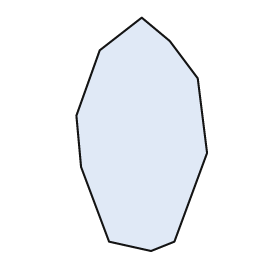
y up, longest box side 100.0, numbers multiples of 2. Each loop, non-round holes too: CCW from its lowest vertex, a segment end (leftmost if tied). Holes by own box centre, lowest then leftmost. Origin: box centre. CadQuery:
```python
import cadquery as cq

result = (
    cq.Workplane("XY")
    .moveTo(4.0, -50.0)
    .lineTo(14.0, -46.0)
    .lineTo(28.0, -8.0)
    .lineTo(24.0, 24.0)
    .lineTo(12.0, 40.0)
    .lineTo(0.0, 50.0)
    .lineTo(-18.0, 36.0)
    .lineTo(-28.0, 8.0)
    .lineTo(-26.0, -14.0)
    .lineTo(-14.0, -46.0)
    .close()
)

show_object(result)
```